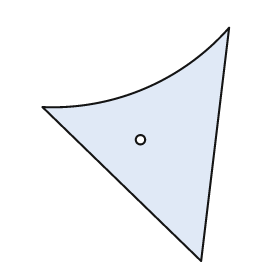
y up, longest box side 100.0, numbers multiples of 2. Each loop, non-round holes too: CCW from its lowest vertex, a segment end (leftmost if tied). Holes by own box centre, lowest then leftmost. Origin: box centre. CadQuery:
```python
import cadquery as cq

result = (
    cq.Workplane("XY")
    .moveTo(28.0, -50.0)
    .lineTo(40.0, 50.0)
    .threePointArc((4.0, 24.0), (-40.0, 16.0))
    .close()
    .moveTo(2.0, 2.0)
    .circle(2.0)
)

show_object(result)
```